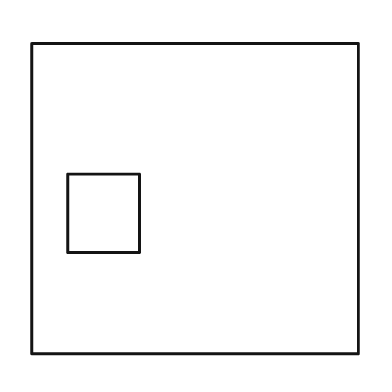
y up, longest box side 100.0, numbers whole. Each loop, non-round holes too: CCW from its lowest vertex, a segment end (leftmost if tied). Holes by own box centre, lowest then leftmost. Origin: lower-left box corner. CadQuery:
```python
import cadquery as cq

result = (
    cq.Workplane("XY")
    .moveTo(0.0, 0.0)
    .lineTo(100.0, 0.0)
    .lineTo(100.0, 95.0)
    .lineTo(0.0, 95.0)
    .close()
    .moveTo(11.0, 31.0)
    .lineTo(33.0, 31.0)
    .lineTo(33.0, 55.0)
    .lineTo(11.0, 55.0)
    .close()
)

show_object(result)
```